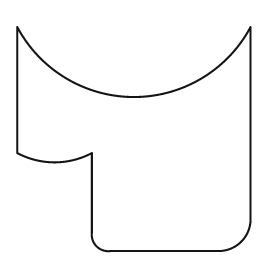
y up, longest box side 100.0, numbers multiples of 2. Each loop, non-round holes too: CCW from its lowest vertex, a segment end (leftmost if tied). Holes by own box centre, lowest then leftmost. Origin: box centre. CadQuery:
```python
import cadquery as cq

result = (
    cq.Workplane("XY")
    .moveTo(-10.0, -48.0)
    .lineTo(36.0, -48.0)
    .threePointArc((46.0, -44.0), (50.0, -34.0))
    .lineTo(50.0, 48.0)
    .threePointArc((0.0, 18.0), (-50.0, 48.0))
    .lineTo(-50.0, -6.0)
    .threePointArc((-34.0, -10.0), (-18.0, -6.0))
    .lineTo(-18.0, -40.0)
    .threePointArc((-16.0, -46.0), (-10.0, -48.0))
    .close()
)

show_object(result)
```